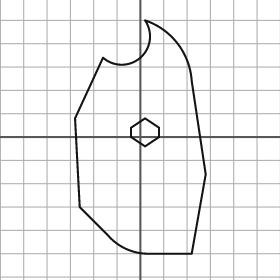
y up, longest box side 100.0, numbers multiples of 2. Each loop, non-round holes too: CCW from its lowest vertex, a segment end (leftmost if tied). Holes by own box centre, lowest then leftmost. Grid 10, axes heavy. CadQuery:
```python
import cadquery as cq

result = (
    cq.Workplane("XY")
    .moveTo(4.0, -50.0)
    .lineTo(22.0, -50.0)
    .lineTo(28.0, -16.0)
    .lineTo(22.0, 24.0)
    .threePointArc((16.0, 40.0), (2.0, 50.0))
    .threePointArc((0.0, 34.0), (-16.0, 34.0))
    .lineTo(-28.0, 8.0)
    .lineTo(-26.0, -30.0)
    .lineTo(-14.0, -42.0)
    .threePointArc((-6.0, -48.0), (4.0, -50.0))
    .close()
    .moveTo(2.0, -4.0)
    .lineTo(8.0, 0.0)
    .lineTo(8.0, 4.0)
    .lineTo(2.0, 8.0)
    .lineTo(-4.0, 4.0)
    .lineTo(-4.0, 0.0)
    .close()
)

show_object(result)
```